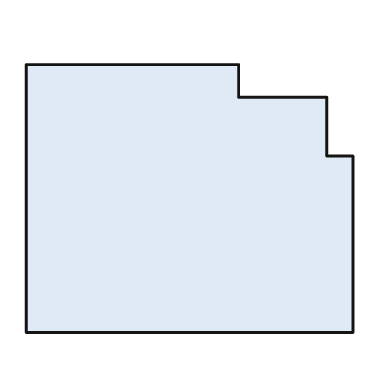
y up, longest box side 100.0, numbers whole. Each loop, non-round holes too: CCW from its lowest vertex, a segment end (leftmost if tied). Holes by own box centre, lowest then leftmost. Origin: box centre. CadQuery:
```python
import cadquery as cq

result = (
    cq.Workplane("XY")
    .moveTo(-50.0, -41.0)
    .lineTo(50.0, -41.0)
    .lineTo(50.0, 13.0)
    .lineTo(42.0, 13.0)
    .lineTo(42.0, 31.0)
    .lineTo(15.0, 31.0)
    .lineTo(15.0, 41.0)
    .lineTo(-50.0, 41.0)
    .close()
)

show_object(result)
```